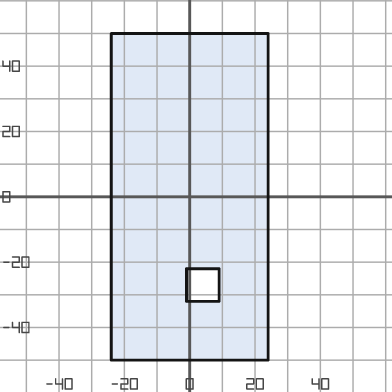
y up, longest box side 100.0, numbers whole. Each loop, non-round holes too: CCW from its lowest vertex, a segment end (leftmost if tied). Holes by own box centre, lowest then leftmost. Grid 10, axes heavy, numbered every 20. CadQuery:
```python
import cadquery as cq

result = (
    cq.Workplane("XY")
    .moveTo(-24.0, -50.0)
    .lineTo(24.0, -50.0)
    .lineTo(24.0, 50.0)
    .lineTo(-24.0, 50.0)
    .close()
    .moveTo(-1.0, -32.0)
    .lineTo(9.0, -32.0)
    .lineTo(9.0, -22.0)
    .lineTo(-1.0, -22.0)
    .close()
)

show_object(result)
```